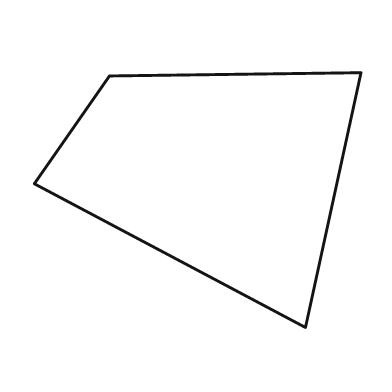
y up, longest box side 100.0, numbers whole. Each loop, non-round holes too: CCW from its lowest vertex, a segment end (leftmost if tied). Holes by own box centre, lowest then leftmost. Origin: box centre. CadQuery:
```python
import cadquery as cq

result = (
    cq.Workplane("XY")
    .moveTo(33.0, -39.0)
    .lineTo(50.0, 39.0)
    .lineTo(-27.0, 38.0)
    .lineTo(-50.0, 5.0)
    .close()
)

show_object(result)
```